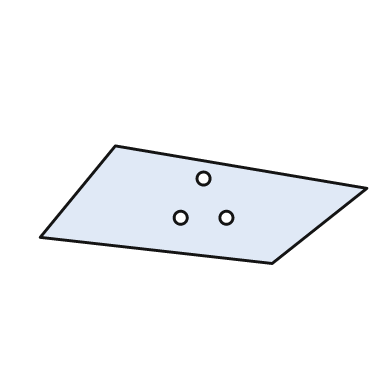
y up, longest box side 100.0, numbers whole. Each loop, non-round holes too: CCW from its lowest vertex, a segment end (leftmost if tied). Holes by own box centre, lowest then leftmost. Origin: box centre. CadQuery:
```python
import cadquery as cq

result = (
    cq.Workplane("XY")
    .moveTo(21.0, -18.0)
    .lineTo(50.0, 5.0)
    .lineTo(-27.0, 18.0)
    .lineTo(-50.0, -10.0)
    .close()
    .moveTo(-7.0, -4.0)
    .circle(2.0)
    .moveTo(7.0, -4.0)
    .circle(2.0)
    .moveTo(0.0, 8.0)
    .circle(2.0)
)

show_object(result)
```